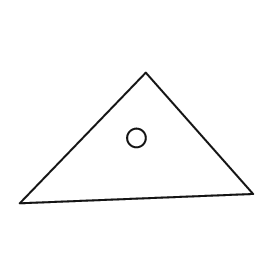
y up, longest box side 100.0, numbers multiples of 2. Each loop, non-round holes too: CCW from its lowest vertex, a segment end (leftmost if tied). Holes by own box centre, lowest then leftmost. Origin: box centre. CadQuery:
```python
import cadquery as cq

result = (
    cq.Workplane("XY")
    .moveTo(-50.0, -28.0)
    .lineTo(50.0, -24.0)
    .lineTo(4.0, 28.0)
    .close()
    .moveTo(0.0, 0.0)
    .circle(4.0)
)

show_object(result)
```